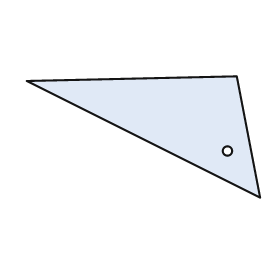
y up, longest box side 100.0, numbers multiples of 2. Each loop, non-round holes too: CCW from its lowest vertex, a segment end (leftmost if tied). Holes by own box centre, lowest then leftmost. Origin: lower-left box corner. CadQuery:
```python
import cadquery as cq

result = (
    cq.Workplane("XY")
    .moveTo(100.0, 0.0)
    .lineTo(90.0, 52.0)
    .lineTo(0.0, 50.0)
    .close()
    .moveTo(86.0, 20.0)
    .circle(2.0)
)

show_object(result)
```